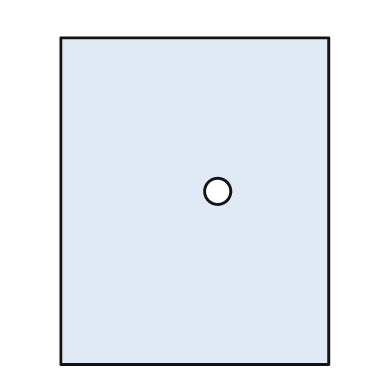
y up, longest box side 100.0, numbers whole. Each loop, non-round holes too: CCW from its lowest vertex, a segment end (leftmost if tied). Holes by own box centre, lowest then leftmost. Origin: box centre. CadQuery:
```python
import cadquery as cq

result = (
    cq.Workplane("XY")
    .moveTo(-41.0, -50.0)
    .lineTo(41.0, -50.0)
    .lineTo(41.0, 50.0)
    .lineTo(-41.0, 50.0)
    .close()
    .moveTo(7.0, 3.0)
    .circle(4.0)
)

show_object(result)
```